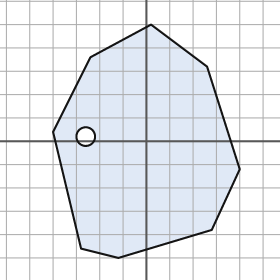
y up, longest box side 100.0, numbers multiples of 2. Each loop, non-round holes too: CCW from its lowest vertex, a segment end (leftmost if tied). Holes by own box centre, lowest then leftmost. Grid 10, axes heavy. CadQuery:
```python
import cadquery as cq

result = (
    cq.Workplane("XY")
    .moveTo(-12.0, -50.0)
    .lineTo(28.0, -38.0)
    .lineTo(40.0, -12.0)
    .lineTo(26.0, 32.0)
    .lineTo(2.0, 50.0)
    .lineTo(-24.0, 36.0)
    .lineTo(-40.0, 4.0)
    .lineTo(-28.0, -46.0)
    .close()
    .moveTo(-26.0, 2.0)
    .circle(4.0)
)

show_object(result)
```